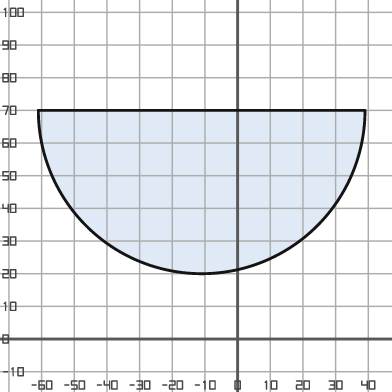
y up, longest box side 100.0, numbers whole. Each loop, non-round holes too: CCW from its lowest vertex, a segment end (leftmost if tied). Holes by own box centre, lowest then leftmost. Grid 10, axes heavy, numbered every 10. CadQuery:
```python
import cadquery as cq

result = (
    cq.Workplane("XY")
    .moveTo(-61.0, 70.0)
    .threePointArc((-11.0, 20.0), (39.0, 70.0))
    .close()
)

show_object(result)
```